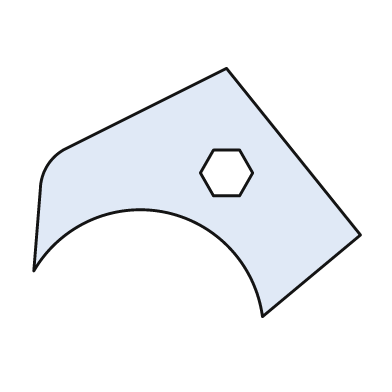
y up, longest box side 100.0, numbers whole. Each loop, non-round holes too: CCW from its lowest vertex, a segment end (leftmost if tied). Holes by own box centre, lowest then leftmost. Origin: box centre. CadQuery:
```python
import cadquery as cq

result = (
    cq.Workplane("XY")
    .moveTo(20.0, -38.0)
    .lineTo(50.0, -13.0)
    .lineTo(9.0, 38.0)
    .lineTo(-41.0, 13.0)
    .threePointArc((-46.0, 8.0), (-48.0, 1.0))
    .lineTo(-50.0, -24.0)
    .threePointArc((-10.0, -6.0), (20.0, -38.0))
    .close()
    .moveTo(5.0, -1.0)
    .lineTo(13.0, -1.0)
    .lineTo(17.0, 6.0)
    .lineTo(13.0, 13.0)
    .lineTo(5.0, 13.0)
    .lineTo(1.0, 6.0)
    .close()
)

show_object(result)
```